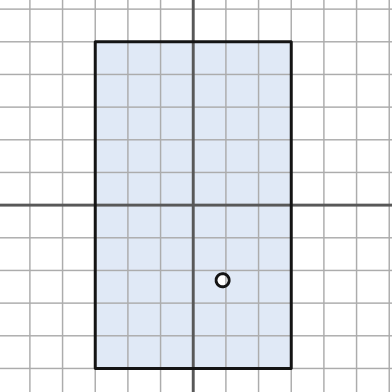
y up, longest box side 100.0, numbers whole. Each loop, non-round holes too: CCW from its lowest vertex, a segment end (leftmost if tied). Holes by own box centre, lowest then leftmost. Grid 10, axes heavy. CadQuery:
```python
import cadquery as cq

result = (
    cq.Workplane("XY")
    .moveTo(-30.0, -50.0)
    .lineTo(30.0, -50.0)
    .lineTo(30.0, 50.0)
    .lineTo(-30.0, 50.0)
    .close()
    .moveTo(9.0, -23.0)
    .circle(2.0)
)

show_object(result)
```